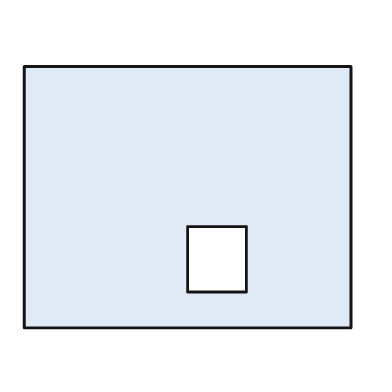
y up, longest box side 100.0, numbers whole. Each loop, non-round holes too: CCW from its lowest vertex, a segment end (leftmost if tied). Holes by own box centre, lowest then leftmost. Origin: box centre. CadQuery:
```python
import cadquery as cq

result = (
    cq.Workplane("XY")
    .moveTo(-50.0, -40.0)
    .lineTo(50.0, -40.0)
    .lineTo(50.0, 40.0)
    .lineTo(-50.0, 40.0)
    .close()
    .moveTo(0.0, -29.0)
    .lineTo(18.0, -29.0)
    .lineTo(18.0, -9.0)
    .lineTo(0.0, -9.0)
    .close()
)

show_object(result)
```